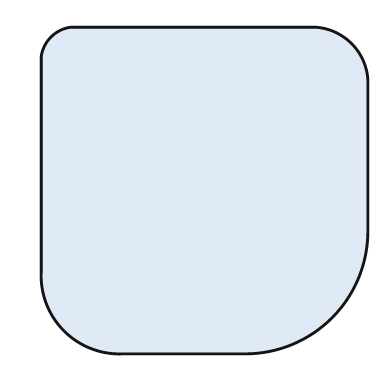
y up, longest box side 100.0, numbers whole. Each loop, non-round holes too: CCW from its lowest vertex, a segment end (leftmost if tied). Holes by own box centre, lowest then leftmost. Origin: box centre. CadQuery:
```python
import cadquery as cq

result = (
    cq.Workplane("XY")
    .moveTo(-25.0, -50.0)
    .lineTo(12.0, -50.0)
    .threePointArc((39.0, -39.0), (50.0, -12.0))
    .lineTo(50.0, 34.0)
    .threePointArc((45.0, 45.0), (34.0, 50.0))
    .lineTo(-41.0, 50.0)
    .threePointArc((-47.0, 47.0), (-50.0, 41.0))
    .lineTo(-50.0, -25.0)
    .threePointArc((-43.0, -43.0), (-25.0, -50.0))
    .close()
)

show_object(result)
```